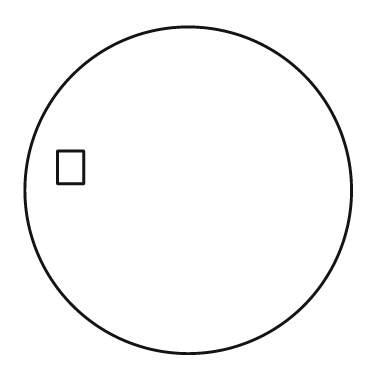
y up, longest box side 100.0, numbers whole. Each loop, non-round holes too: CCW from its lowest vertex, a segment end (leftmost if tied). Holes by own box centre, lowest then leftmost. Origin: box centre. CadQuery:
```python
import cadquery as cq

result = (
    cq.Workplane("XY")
    .moveTo(0.0, 0.0)
    .circle(50.0)
    .moveTo(-40.0, 2.0)
    .lineTo(-32.0, 2.0)
    .lineTo(-32.0, 12.0)
    .lineTo(-40.0, 12.0)
    .close()
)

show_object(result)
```